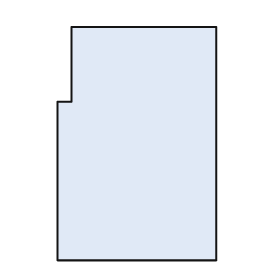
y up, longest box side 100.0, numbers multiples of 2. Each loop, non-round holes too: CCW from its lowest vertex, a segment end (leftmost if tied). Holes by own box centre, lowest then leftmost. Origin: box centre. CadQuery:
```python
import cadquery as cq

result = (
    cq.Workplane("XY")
    .moveTo(-34.0, -50.0)
    .lineTo(34.0, -50.0)
    .lineTo(34.0, 50.0)
    .lineTo(-28.0, 50.0)
    .lineTo(-28.0, 18.0)
    .lineTo(-34.0, 18.0)
    .close()
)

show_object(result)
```